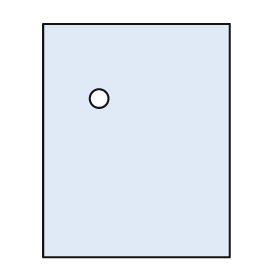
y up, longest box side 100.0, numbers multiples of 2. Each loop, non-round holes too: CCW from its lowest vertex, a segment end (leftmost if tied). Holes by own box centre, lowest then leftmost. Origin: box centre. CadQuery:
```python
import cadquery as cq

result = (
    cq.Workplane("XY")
    .moveTo(-40.0, -50.0)
    .lineTo(40.0, -50.0)
    .lineTo(40.0, 50.0)
    .lineTo(-40.0, 50.0)
    .close()
    .moveTo(-16.0, 18.0)
    .circle(4.0)
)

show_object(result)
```